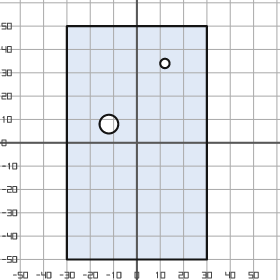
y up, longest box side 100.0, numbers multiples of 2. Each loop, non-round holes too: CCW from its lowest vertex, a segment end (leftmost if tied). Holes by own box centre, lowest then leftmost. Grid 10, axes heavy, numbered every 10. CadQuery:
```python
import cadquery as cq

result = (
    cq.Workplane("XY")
    .moveTo(-30.0, -50.0)
    .lineTo(30.0, -50.0)
    .lineTo(30.0, 50.0)
    .lineTo(-30.0, 50.0)
    .close()
    .moveTo(-12.0, 8.0)
    .circle(4.0)
    .moveTo(12.0, 34.0)
    .circle(2.0)
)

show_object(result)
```